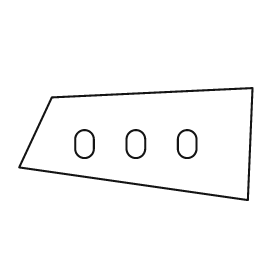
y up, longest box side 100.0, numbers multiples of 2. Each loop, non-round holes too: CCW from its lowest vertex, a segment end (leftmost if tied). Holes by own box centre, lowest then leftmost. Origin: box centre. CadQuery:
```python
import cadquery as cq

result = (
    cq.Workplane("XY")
    .moveTo(48.0, -24.0)
    .lineTo(50.0, 24.0)
    .lineTo(-36.0, 20.0)
    .lineTo(-50.0, -10.0)
    .close()
    .moveTo(-26.0, -2.0)
    .threePointArc((-22.0, -6.0), (-18.0, -2.0))
    .lineTo(-18.0, 2.0)
    .threePointArc((-22.0, 6.0), (-26.0, 2.0))
    .close()
    .moveTo(-4.0, -2.0)
    .threePointArc((0.0, -6.0), (4.0, -2.0))
    .lineTo(4.0, 2.0)
    .threePointArc((0.0, 6.0), (-4.0, 2.0))
    .close()
    .moveTo(18.0, -2.0)
    .threePointArc((22.0, -6.0), (26.0, -2.0))
    .lineTo(26.0, 2.0)
    .threePointArc((22.0, 6.0), (18.0, 2.0))
    .close()
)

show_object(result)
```